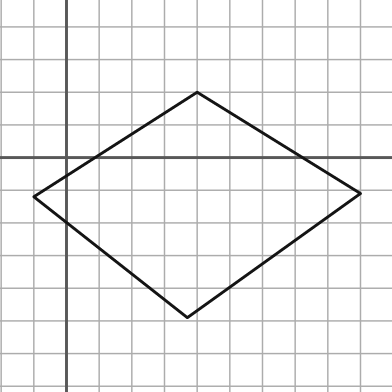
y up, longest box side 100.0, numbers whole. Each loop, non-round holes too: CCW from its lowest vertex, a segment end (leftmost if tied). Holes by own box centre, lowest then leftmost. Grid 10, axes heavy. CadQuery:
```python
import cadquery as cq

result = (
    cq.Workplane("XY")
    .moveTo(37.0, -49.0)
    .lineTo(90.0, -11.0)
    .lineTo(40.0, 20.0)
    .lineTo(-10.0, -12.0)
    .close()
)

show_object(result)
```